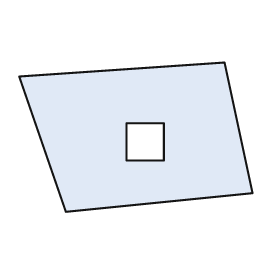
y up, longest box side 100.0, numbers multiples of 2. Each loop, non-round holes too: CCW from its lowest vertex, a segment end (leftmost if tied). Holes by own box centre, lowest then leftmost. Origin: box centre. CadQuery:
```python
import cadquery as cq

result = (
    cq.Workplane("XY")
    .moveTo(-30.0, -32.0)
    .lineTo(50.0, -24.0)
    .lineTo(38.0, 32.0)
    .lineTo(-50.0, 26.0)
    .close()
    .moveTo(-4.0, -10.0)
    .lineTo(12.0, -10.0)
    .lineTo(12.0, 6.0)
    .lineTo(-4.0, 6.0)
    .close()
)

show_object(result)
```